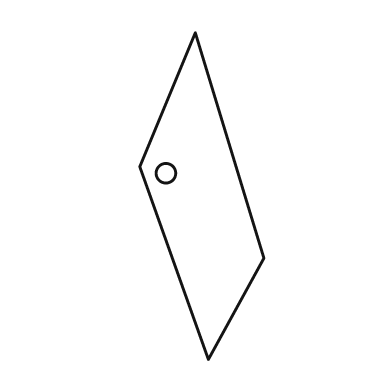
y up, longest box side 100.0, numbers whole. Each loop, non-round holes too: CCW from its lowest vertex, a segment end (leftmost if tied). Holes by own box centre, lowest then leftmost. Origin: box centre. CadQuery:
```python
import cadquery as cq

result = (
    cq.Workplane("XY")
    .moveTo(2.0, -50.0)
    .lineTo(19.0, -19.0)
    .lineTo(-2.0, 50.0)
    .lineTo(-19.0, 9.0)
    .close()
    .moveTo(-11.0, 7.0)
    .circle(3.0)
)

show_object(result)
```